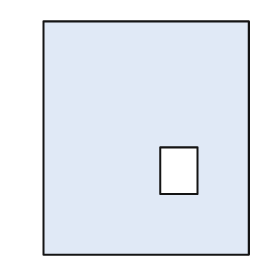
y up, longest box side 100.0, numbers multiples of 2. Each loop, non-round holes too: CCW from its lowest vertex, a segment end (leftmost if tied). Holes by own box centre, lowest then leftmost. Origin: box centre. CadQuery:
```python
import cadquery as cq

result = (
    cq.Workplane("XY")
    .moveTo(-44.0, -50.0)
    .lineTo(44.0, -50.0)
    .lineTo(44.0, 50.0)
    .lineTo(-44.0, 50.0)
    .close()
    .moveTo(6.0, -24.0)
    .lineTo(22.0, -24.0)
    .lineTo(22.0, -4.0)
    .lineTo(6.0, -4.0)
    .close()
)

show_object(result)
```